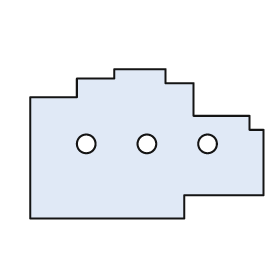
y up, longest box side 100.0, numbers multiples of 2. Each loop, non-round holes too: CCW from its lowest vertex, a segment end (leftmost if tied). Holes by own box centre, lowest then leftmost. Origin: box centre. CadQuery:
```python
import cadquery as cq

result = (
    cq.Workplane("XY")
    .moveTo(-50.0, -32.0)
    .lineTo(16.0, -32.0)
    .lineTo(16.0, -22.0)
    .lineTo(50.0, -22.0)
    .lineTo(50.0, 6.0)
    .lineTo(44.0, 6.0)
    .lineTo(44.0, 12.0)
    .lineTo(20.0, 12.0)
    .lineTo(20.0, 26.0)
    .lineTo(8.0, 26.0)
    .lineTo(8.0, 32.0)
    .lineTo(-14.0, 32.0)
    .lineTo(-14.0, 28.0)
    .lineTo(-30.0, 28.0)
    .lineTo(-30.0, 20.0)
    .lineTo(-50.0, 20.0)
    .close()
    .moveTo(-26.0, 0.0)
    .circle(4.0)
    .moveTo(0.0, 0.0)
    .circle(4.0)
    .moveTo(26.0, 0.0)
    .circle(4.0)
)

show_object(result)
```